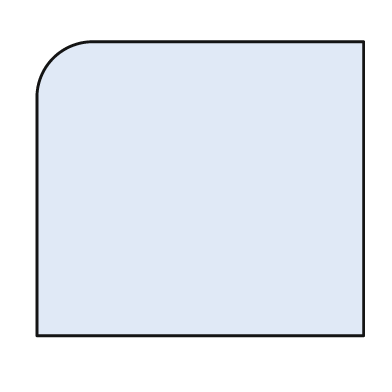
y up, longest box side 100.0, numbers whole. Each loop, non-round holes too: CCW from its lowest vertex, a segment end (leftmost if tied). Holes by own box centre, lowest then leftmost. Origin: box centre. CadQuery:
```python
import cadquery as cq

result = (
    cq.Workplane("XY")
    .moveTo(-50.0, -45.0)
    .lineTo(50.0, -45.0)
    .lineTo(50.0, 45.0)
    .lineTo(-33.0, 45.0)
    .threePointArc((-45.0, 40.0), (-50.0, 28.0))
    .close()
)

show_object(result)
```